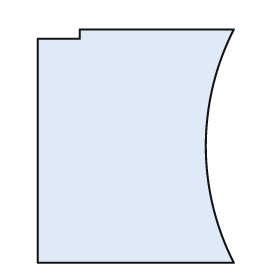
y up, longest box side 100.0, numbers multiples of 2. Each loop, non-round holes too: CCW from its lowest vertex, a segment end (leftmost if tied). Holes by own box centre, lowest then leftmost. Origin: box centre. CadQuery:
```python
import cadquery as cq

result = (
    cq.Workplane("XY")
    .moveTo(-42.0, -50.0)
    .lineTo(42.0, -50.0)
    .threePointArc((30.0, 0.0), (42.0, 50.0))
    .lineTo(-24.0, 50.0)
    .lineTo(-24.0, 46.0)
    .lineTo(-42.0, 46.0)
    .close()
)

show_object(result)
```